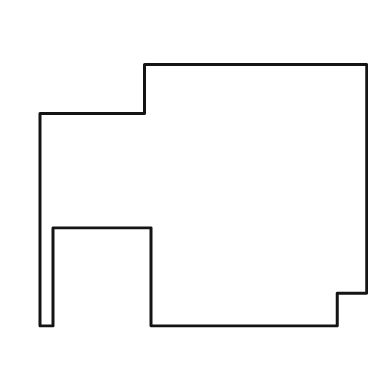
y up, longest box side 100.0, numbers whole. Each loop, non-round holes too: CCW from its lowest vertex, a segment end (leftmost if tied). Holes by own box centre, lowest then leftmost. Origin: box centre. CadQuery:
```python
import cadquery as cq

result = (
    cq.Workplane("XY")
    .moveTo(-50.0, -40.0)
    .lineTo(-46.0, -40.0)
    .lineTo(-46.0, -10.0)
    .lineTo(-16.0, -10.0)
    .lineTo(-16.0, -40.0)
    .lineTo(41.0, -40.0)
    .lineTo(41.0, -30.0)
    .lineTo(50.0, -30.0)
    .lineTo(50.0, 40.0)
    .lineTo(-18.0, 40.0)
    .lineTo(-18.0, 25.0)
    .lineTo(-50.0, 25.0)
    .close()
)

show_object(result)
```